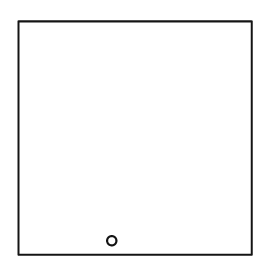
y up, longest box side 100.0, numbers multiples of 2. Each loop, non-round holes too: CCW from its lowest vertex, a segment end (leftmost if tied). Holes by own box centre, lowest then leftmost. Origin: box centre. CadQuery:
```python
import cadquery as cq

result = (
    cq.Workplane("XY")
    .moveTo(-50.0, -50.0)
    .lineTo(50.0, -50.0)
    .lineTo(50.0, 50.0)
    .lineTo(-50.0, 50.0)
    .close()
    .moveTo(-10.0, -44.0)
    .circle(2.0)
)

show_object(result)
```